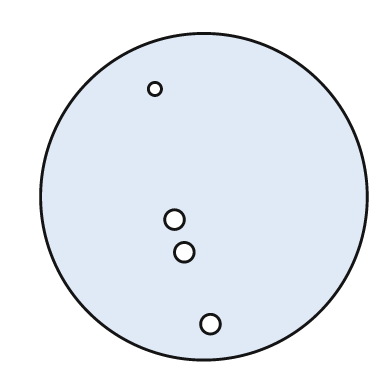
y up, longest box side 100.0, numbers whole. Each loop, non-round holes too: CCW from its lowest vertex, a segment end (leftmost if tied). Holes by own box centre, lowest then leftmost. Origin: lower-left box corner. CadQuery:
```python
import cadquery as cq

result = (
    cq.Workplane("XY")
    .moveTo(50.0, 50.0)
    .circle(50.0)
    .moveTo(52.0, 11.0)
    .circle(3.0)
    .moveTo(44.0, 33.0)
    .circle(3.0)
    .moveTo(41.0, 43.0)
    .circle(3.0)
    .moveTo(35.0, 83.0)
    .circle(2.0)
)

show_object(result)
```